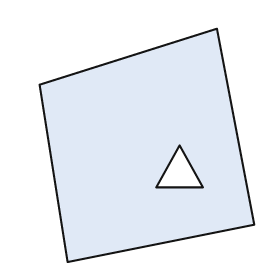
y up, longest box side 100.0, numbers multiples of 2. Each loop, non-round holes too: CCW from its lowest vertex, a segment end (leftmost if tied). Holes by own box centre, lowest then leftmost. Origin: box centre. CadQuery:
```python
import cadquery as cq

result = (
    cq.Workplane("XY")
    .moveTo(-34.0, -50.0)
    .lineTo(46.0, -34.0)
    .lineTo(30.0, 50.0)
    .lineTo(-46.0, 26.0)
    .close()
    .moveTo(4.0, -18.0)
    .lineTo(24.0, -18.0)
    .lineTo(14.0, 0.0)
    .close()
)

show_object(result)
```